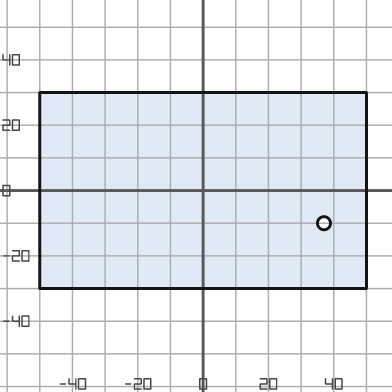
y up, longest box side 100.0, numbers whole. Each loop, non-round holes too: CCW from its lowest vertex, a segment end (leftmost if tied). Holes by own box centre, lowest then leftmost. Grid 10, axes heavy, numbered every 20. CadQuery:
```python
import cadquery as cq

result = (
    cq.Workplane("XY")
    .moveTo(-50.0, -30.0)
    .lineTo(50.0, -30.0)
    .lineTo(50.0, 30.0)
    .lineTo(-50.0, 30.0)
    .close()
    .moveTo(37.0, -10.0)
    .circle(2.0)
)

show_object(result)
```